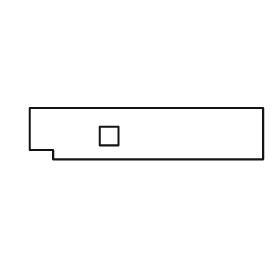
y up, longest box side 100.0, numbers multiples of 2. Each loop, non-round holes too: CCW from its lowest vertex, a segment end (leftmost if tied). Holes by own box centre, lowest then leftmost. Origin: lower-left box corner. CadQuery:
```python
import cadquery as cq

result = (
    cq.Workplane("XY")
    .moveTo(10.0, 0.0)
    .lineTo(100.0, 0.0)
    .lineTo(100.0, 22.0)
    .lineTo(0.0, 22.0)
    .lineTo(0.0, 4.0)
    .lineTo(10.0, 4.0)
    .close()
    .moveTo(30.0, 6.0)
    .lineTo(38.0, 6.0)
    .lineTo(38.0, 14.0)
    .lineTo(30.0, 14.0)
    .close()
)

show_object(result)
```